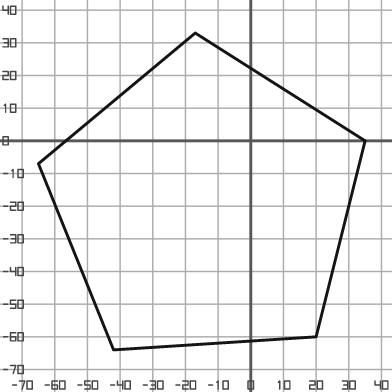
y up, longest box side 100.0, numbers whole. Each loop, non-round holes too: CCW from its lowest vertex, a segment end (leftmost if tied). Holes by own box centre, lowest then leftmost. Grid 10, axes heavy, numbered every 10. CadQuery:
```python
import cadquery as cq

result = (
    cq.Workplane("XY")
    .moveTo(-42.0, -64.0)
    .lineTo(20.0, -60.0)
    .lineTo(35.0, 0.0)
    .lineTo(-17.0, 33.0)
    .lineTo(-65.0, -7.0)
    .close()
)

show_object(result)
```